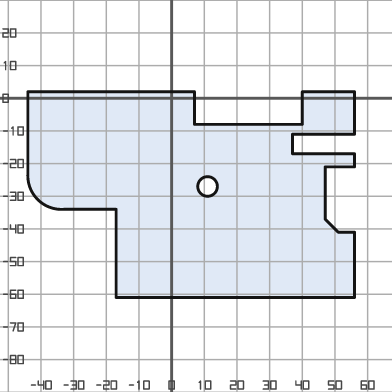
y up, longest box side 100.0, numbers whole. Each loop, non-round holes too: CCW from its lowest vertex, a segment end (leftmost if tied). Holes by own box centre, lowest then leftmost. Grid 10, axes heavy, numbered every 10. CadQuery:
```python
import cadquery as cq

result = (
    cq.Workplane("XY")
    .moveTo(-17.0, -61.0)
    .lineTo(56.0, -61.0)
    .lineTo(56.0, -41.0)
    .lineTo(51.0, -41.0)
    .lineTo(47.0, -37.0)
    .lineTo(47.0, -21.0)
    .lineTo(56.0, -21.0)
    .lineTo(56.0, -17.0)
    .lineTo(37.0, -17.0)
    .lineTo(37.0, -11.0)
    .lineTo(56.0, -11.0)
    .lineTo(56.0, 2.0)
    .lineTo(40.0, 2.0)
    .lineTo(40.0, -8.0)
    .lineTo(7.0, -8.0)
    .lineTo(7.0, 2.0)
    .lineTo(-44.0, 2.0)
    .lineTo(-44.0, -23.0)
    .threePointArc((-41.0, -31.0), (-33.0, -34.0))
    .lineTo(-17.0, -34.0)
    .close()
    .moveTo(11.0, -27.0)
    .circle(3.0)
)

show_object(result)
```